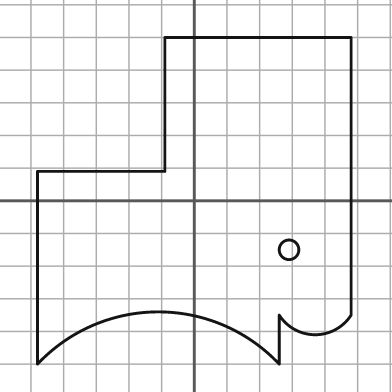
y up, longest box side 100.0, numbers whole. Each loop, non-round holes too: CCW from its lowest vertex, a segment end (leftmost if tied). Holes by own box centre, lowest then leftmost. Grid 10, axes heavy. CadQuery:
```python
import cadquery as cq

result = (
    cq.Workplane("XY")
    .moveTo(-48.0, -50.0)
    .threePointArc((-11.0, -34.0), (26.0, -50.0))
    .lineTo(26.0, -35.0)
    .threePointArc((37.0, -41.0), (48.0, -35.0))
    .lineTo(48.0, 50.0)
    .lineTo(-9.0, 50.0)
    .lineTo(-9.0, 9.0)
    .lineTo(-48.0, 9.0)
    .close()
    .moveTo(29.0, -15.0)
    .circle(3.0)
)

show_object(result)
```